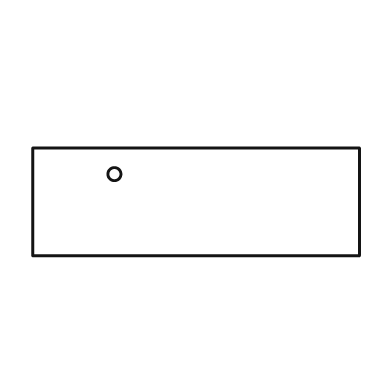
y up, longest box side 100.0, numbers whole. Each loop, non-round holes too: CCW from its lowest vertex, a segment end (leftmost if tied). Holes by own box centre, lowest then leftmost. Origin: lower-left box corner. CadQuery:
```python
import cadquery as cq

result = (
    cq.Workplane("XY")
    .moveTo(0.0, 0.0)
    .lineTo(100.0, 0.0)
    .lineTo(100.0, 33.0)
    .lineTo(0.0, 33.0)
    .close()
    .moveTo(25.0, 25.0)
    .circle(2.0)
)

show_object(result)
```